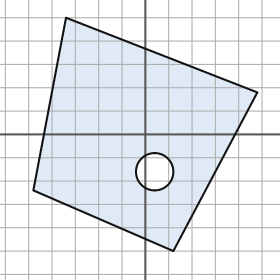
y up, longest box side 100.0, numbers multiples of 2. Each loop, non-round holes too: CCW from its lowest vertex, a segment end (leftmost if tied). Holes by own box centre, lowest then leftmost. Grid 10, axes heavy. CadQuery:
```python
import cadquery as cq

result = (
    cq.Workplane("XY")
    .moveTo(12.0, -50.0)
    .lineTo(48.0, 18.0)
    .lineTo(-34.0, 50.0)
    .lineTo(-48.0, -24.0)
    .close()
    .moveTo(4.0, -16.0)
    .circle(8.0)
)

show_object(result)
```